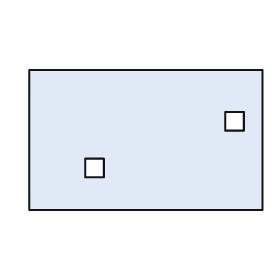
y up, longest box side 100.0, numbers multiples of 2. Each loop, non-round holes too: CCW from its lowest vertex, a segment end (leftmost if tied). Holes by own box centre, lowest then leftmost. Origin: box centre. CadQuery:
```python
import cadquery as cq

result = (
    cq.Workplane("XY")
    .moveTo(-50.0, -30.0)
    .lineTo(50.0, -30.0)
    .lineTo(50.0, 30.0)
    .lineTo(-50.0, 30.0)
    .close()
    .moveTo(-26.0, -16.0)
    .lineTo(-18.0, -16.0)
    .lineTo(-18.0, -8.0)
    .lineTo(-26.0, -8.0)
    .close()
    .moveTo(34.0, 4.0)
    .lineTo(42.0, 4.0)
    .lineTo(42.0, 12.0)
    .lineTo(34.0, 12.0)
    .close()
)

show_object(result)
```